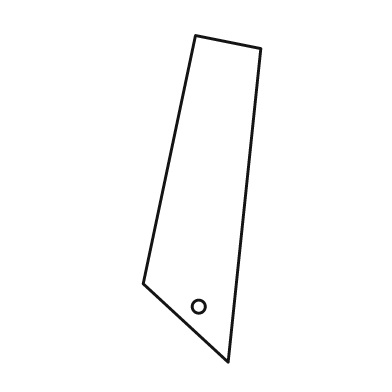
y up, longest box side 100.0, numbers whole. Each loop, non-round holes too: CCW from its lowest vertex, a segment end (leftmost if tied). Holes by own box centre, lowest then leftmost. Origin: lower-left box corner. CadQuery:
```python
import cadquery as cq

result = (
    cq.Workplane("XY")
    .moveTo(26.0, 0.0)
    .lineTo(36.0, 96.0)
    .lineTo(16.0, 100.0)
    .lineTo(0.0, 24.0)
    .close()
    .moveTo(17.0, 17.0)
    .circle(2.0)
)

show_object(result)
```